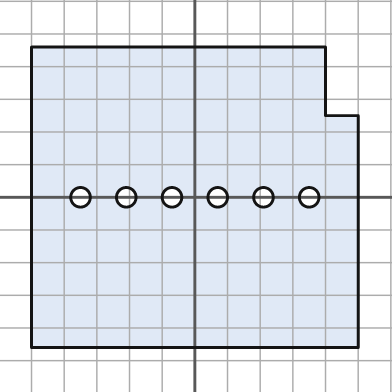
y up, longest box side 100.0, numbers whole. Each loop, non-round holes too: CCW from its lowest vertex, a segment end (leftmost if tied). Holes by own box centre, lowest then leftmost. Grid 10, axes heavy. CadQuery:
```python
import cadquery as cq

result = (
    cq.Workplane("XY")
    .moveTo(-50.0, -46.0)
    .lineTo(50.0, -46.0)
    .lineTo(50.0, 25.0)
    .lineTo(40.0, 25.0)
    .lineTo(40.0, 46.0)
    .lineTo(-50.0, 46.0)
    .close()
    .moveTo(-35.0, 0.0)
    .circle(3.0)
    .moveTo(-21.0, 0.0)
    .circle(3.0)
    .moveTo(-7.0, 0.0)
    .circle(3.0)
    .moveTo(7.0, 0.0)
    .circle(3.0)
    .moveTo(21.0, 0.0)
    .circle(3.0)
    .moveTo(35.0, 0.0)
    .circle(3.0)
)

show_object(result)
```